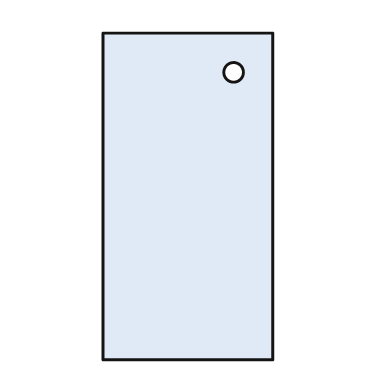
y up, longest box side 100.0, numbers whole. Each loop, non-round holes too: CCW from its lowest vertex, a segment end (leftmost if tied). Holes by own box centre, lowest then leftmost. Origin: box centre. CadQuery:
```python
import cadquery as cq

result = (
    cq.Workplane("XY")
    .moveTo(-26.0, -50.0)
    .lineTo(26.0, -50.0)
    .lineTo(26.0, 50.0)
    .lineTo(-26.0, 50.0)
    .close()
    .moveTo(14.0, 38.0)
    .circle(3.0)
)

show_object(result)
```